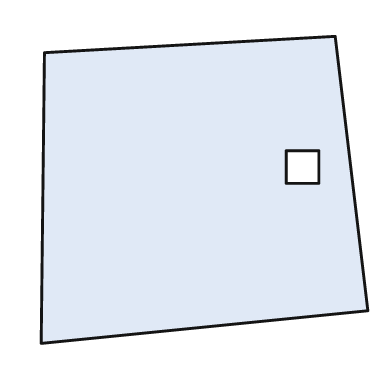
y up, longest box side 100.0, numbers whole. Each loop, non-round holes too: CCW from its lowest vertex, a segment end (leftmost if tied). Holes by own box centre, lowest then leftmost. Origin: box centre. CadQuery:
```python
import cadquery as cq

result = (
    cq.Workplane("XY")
    .moveTo(-50.0, -47.0)
    .lineTo(50.0, -37.0)
    .lineTo(40.0, 47.0)
    .lineTo(-49.0, 42.0)
    .close()
    .moveTo(25.0, 2.0)
    .lineTo(35.0, 2.0)
    .lineTo(35.0, 12.0)
    .lineTo(25.0, 12.0)
    .close()
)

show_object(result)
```